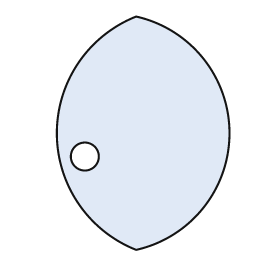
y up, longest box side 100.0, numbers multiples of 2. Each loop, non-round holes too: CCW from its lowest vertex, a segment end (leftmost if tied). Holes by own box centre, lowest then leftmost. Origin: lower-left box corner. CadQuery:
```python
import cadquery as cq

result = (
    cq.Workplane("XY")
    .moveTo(34.0, 0.0)
    .threePointArc((74.0, 50.0), (34.0, 100.0))
    .threePointArc((0.0, 50.0), (34.0, 0.0))
    .close()
    .moveTo(12.0, 40.0)
    .circle(6.0)
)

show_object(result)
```